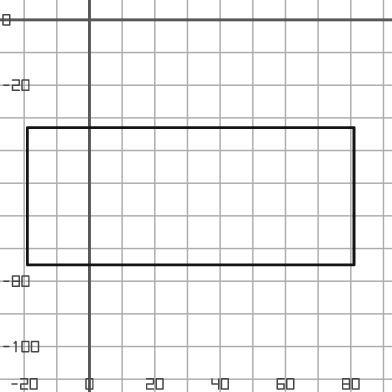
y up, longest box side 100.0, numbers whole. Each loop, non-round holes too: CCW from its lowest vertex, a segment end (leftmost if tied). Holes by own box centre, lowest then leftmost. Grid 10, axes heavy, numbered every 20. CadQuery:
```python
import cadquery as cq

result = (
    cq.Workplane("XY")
    .moveTo(-19.0, -75.0)
    .lineTo(81.0, -75.0)
    .lineTo(81.0, -33.0)
    .lineTo(-19.0, -33.0)
    .close()
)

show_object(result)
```